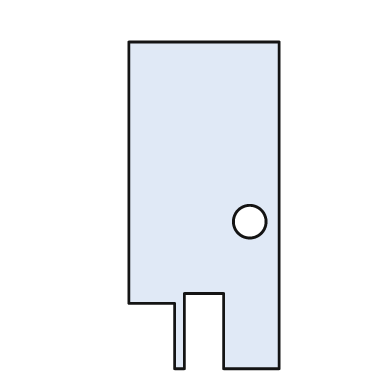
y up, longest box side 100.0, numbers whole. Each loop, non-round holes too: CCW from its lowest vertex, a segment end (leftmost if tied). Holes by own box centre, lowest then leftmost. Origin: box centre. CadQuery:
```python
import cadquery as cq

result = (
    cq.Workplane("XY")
    .moveTo(-9.0, -50.0)
    .lineTo(-6.0, -50.0)
    .lineTo(-6.0, -27.0)
    .lineTo(6.0, -27.0)
    .lineTo(6.0, -50.0)
    .lineTo(23.0, -50.0)
    .lineTo(23.0, 50.0)
    .lineTo(-23.0, 50.0)
    .lineTo(-23.0, -30.0)
    .lineTo(-9.0, -30.0)
    .close()
    .moveTo(14.0, -5.0)
    .circle(5.0)
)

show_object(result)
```